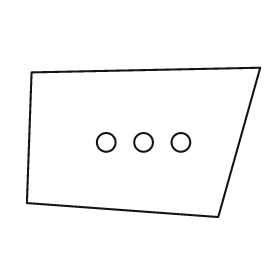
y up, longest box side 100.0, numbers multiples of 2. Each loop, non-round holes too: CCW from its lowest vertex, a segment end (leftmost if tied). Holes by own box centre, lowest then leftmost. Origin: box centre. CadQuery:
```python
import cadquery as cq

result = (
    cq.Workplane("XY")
    .moveTo(32.0, -32.0)
    .lineTo(50.0, 32.0)
    .lineTo(-48.0, 30.0)
    .lineTo(-50.0, -26.0)
    .close()
    .moveTo(-16.0, 0.0)
    .circle(4.0)
    .moveTo(0.0, 0.0)
    .circle(4.0)
    .moveTo(16.0, 0.0)
    .circle(4.0)
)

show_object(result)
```